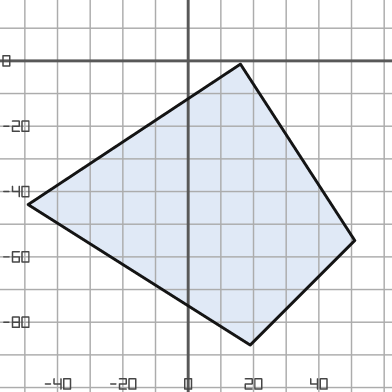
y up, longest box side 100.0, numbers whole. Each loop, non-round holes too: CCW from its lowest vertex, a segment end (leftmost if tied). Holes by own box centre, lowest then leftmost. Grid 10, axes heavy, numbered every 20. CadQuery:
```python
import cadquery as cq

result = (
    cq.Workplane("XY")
    .moveTo(19.0, -87.0)
    .lineTo(51.0, -55.0)
    .lineTo(16.0, -1.0)
    .lineTo(-49.0, -44.0)
    .close()
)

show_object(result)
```